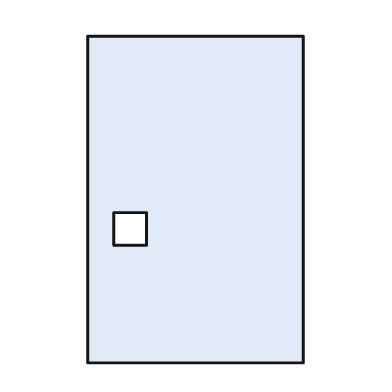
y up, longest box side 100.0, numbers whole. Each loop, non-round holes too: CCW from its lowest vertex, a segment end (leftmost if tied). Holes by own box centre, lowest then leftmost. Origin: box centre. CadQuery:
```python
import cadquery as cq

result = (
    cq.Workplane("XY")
    .moveTo(-33.0, -50.0)
    .lineTo(33.0, -50.0)
    .lineTo(33.0, 50.0)
    .lineTo(-33.0, 50.0)
    .close()
    .moveTo(-25.0, -14.0)
    .lineTo(-15.0, -14.0)
    .lineTo(-15.0, -4.0)
    .lineTo(-25.0, -4.0)
    .close()
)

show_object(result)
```